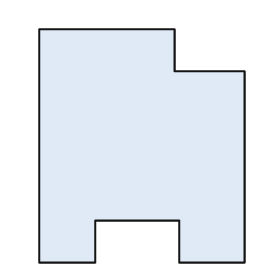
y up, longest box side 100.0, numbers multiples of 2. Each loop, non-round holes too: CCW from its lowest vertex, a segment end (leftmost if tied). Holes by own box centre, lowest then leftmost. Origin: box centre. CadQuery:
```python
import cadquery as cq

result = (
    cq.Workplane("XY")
    .moveTo(-44.0, -50.0)
    .lineTo(-20.0, -50.0)
    .lineTo(-20.0, -32.0)
    .lineTo(16.0, -32.0)
    .lineTo(16.0, -50.0)
    .lineTo(44.0, -50.0)
    .lineTo(44.0, 32.0)
    .lineTo(14.0, 32.0)
    .lineTo(14.0, 50.0)
    .lineTo(-44.0, 50.0)
    .close()
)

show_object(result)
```